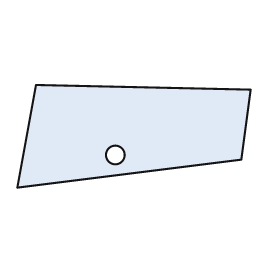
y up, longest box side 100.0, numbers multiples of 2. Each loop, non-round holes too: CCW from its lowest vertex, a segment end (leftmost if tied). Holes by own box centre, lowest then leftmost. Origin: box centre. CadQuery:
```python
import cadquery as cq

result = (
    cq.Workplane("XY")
    .moveTo(-50.0, -22.0)
    .lineTo(46.0, -10.0)
    .lineTo(50.0, 20.0)
    .lineTo(-42.0, 22.0)
    .close()
    .moveTo(-8.0, -8.0)
    .circle(4.0)
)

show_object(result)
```